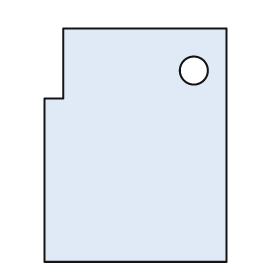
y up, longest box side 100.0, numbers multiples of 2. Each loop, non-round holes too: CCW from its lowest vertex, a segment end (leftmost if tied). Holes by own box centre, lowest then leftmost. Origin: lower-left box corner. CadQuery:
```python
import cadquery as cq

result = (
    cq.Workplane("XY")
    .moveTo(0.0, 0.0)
    .lineTo(78.0, 0.0)
    .lineTo(78.0, 100.0)
    .lineTo(8.0, 100.0)
    .lineTo(8.0, 70.0)
    .lineTo(0.0, 70.0)
    .close()
    .moveTo(64.0, 82.0)
    .circle(6.0)
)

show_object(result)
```